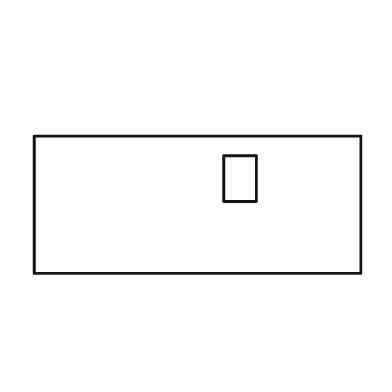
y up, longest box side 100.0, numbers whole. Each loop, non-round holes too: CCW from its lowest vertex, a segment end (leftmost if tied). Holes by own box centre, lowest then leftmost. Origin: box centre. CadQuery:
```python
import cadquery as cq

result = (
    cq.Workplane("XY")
    .moveTo(-50.0, -21.0)
    .lineTo(50.0, -21.0)
    .lineTo(50.0, 21.0)
    .lineTo(-50.0, 21.0)
    .close()
    .moveTo(8.0, 1.0)
    .lineTo(18.0, 1.0)
    .lineTo(18.0, 15.0)
    .lineTo(8.0, 15.0)
    .close()
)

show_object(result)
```